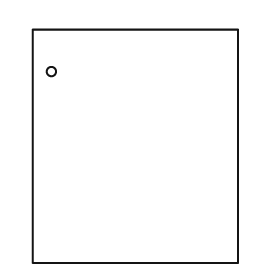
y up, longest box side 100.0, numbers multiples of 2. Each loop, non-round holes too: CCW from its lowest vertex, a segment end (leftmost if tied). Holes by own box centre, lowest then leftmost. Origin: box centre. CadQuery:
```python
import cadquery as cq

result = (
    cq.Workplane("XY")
    .moveTo(-44.0, -50.0)
    .lineTo(44.0, -50.0)
    .lineTo(44.0, 50.0)
    .lineTo(-44.0, 50.0)
    .close()
    .moveTo(-36.0, 32.0)
    .circle(2.0)
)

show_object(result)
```